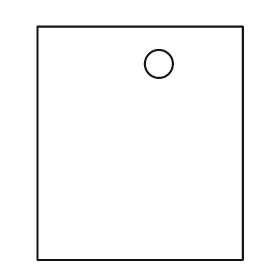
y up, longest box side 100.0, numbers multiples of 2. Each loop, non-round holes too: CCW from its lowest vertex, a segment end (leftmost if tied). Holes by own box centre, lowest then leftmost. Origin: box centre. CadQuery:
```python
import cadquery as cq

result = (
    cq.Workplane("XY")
    .moveTo(-44.0, -50.0)
    .lineTo(44.0, -50.0)
    .lineTo(44.0, 50.0)
    .lineTo(-44.0, 50.0)
    .close()
    .moveTo(8.0, 34.0)
    .circle(6.0)
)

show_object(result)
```